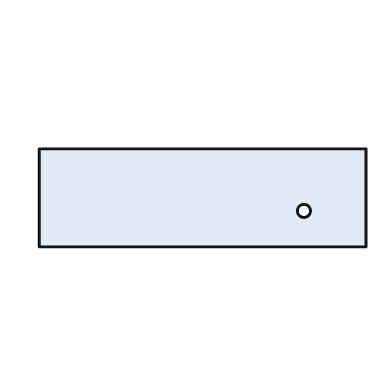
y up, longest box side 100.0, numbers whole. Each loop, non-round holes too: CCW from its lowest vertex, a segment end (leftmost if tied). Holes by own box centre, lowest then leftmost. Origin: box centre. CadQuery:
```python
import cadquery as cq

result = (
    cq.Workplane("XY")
    .moveTo(-50.0, -15.0)
    .lineTo(50.0, -15.0)
    .lineTo(50.0, 15.0)
    .lineTo(-50.0, 15.0)
    .close()
    .moveTo(31.0, -4.0)
    .circle(2.0)
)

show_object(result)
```